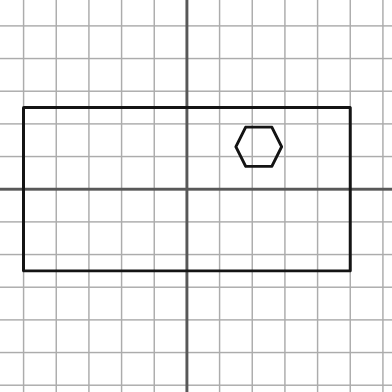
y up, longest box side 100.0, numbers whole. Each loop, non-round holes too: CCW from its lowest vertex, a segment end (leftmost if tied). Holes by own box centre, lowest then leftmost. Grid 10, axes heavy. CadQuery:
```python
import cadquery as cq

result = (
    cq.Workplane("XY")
    .moveTo(-50.0, -25.0)
    .lineTo(50.0, -25.0)
    .lineTo(50.0, 25.0)
    .lineTo(-50.0, 25.0)
    .close()
    .moveTo(18.0, 7.0)
    .lineTo(26.0, 7.0)
    .lineTo(29.0, 13.0)
    .lineTo(26.0, 19.0)
    .lineTo(18.0, 19.0)
    .lineTo(15.0, 13.0)
    .close()
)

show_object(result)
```